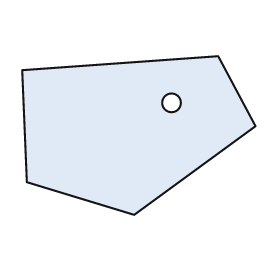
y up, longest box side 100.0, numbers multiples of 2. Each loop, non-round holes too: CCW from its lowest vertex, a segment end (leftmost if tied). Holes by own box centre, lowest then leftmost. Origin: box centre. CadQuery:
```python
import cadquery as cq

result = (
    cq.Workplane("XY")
    .moveTo(-2.0, -34.0)
    .lineTo(50.0, 4.0)
    .lineTo(34.0, 34.0)
    .lineTo(-50.0, 28.0)
    .lineTo(-48.0, -20.0)
    .close()
    .moveTo(14.0, 14.0)
    .circle(4.0)
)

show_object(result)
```